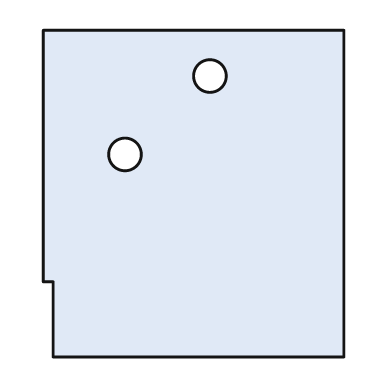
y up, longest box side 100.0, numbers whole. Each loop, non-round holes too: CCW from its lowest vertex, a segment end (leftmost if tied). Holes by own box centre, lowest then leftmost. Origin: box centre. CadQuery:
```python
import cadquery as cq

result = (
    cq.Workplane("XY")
    .moveTo(-43.0, -50.0)
    .lineTo(46.0, -50.0)
    .lineTo(46.0, 50.0)
    .lineTo(-46.0, 50.0)
    .lineTo(-46.0, -27.0)
    .lineTo(-43.0, -27.0)
    .close()
    .moveTo(-21.0, 12.0)
    .circle(5.0)
    .moveTo(5.0, 36.0)
    .circle(5.0)
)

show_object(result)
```